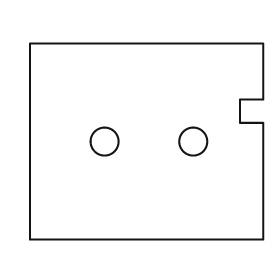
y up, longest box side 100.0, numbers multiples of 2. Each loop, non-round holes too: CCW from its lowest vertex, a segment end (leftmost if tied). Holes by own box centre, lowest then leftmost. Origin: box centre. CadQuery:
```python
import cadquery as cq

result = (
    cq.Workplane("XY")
    .moveTo(-50.0, -42.0)
    .lineTo(50.0, -42.0)
    .lineTo(50.0, 8.0)
    .lineTo(40.0, 8.0)
    .lineTo(40.0, 18.0)
    .lineTo(50.0, 18.0)
    .lineTo(50.0, 42.0)
    .lineTo(-50.0, 42.0)
    .close()
    .moveTo(-18.0, 0.0)
    .circle(6.0)
    .moveTo(20.0, 0.0)
    .circle(6.0)
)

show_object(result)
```